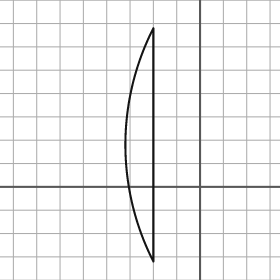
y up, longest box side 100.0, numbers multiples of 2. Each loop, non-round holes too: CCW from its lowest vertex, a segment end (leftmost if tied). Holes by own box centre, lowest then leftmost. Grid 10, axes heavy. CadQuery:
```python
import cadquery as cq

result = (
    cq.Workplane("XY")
    .moveTo(-20.0, -32.0)
    .lineTo(-20.0, 68.0)
    .threePointArc((-32.0, 18.0), (-20.0, -32.0))
    .close()
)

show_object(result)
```